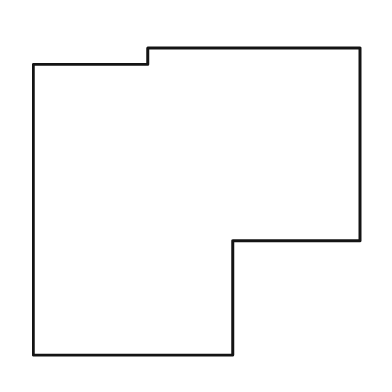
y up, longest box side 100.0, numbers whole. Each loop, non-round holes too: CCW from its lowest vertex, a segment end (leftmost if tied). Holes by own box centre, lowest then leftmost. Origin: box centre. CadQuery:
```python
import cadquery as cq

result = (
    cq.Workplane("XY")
    .moveTo(-50.0, -47.0)
    .lineTo(11.0, -47.0)
    .lineTo(11.0, -12.0)
    .lineTo(50.0, -12.0)
    .lineTo(50.0, 47.0)
    .lineTo(-15.0, 47.0)
    .lineTo(-15.0, 42.0)
    .lineTo(-50.0, 42.0)
    .close()
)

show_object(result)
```